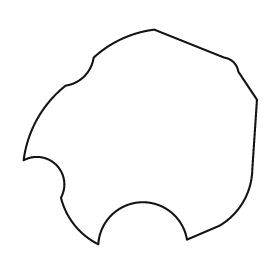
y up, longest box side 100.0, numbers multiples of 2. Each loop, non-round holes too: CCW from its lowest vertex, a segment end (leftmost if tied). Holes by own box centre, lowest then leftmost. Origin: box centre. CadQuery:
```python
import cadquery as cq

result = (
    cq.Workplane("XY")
    .moveTo(-18.0, -46.0)
    .threePointArc((0.0, -28.0), (20.0, -44.0))
    .lineTo(34.0, -38.0)
    .threePointArc((44.0, -28.0), (48.0, -14.0))
    .lineTo(50.0, 16.0)
    .lineTo(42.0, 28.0)
    .threePointArc((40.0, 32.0), (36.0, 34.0))
    .lineTo(6.0, 46.0)
    .threePointArc((-8.0, 42.0), (-20.0, 34.0))
    .threePointArc((-24.0, 26.0), (-32.0, 22.0))
    .threePointArc((-44.0, 8.0), (-50.0, -10.0))
    .threePointArc((-36.0, -12.0), (-34.0, -26.0))
    .threePointArc((-28.0, -38.0), (-18.0, -46.0))
    .close()
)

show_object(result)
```